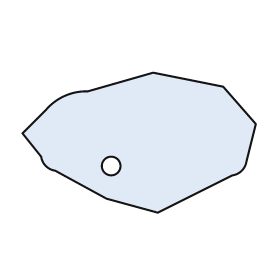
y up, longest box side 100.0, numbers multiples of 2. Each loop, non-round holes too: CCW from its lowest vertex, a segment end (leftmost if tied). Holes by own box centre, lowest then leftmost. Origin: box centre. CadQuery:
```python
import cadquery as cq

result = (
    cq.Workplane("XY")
    .moveTo(8.0, -30.0)
    .lineTo(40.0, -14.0)
    .threePointArc((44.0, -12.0), (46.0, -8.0))
    .lineTo(50.0, 8.0)
    .lineTo(36.0, 24.0)
    .lineTo(6.0, 30.0)
    .lineTo(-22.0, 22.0)
    .threePointArc((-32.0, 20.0), (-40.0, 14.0))
    .lineTo(-50.0, 4.0)
    .lineTo(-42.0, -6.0)
    .threePointArc((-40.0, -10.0), (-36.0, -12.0))
    .lineTo(-14.0, -24.0)
    .close()
    .moveTo(-12.0, -10.0)
    .circle(4.0)
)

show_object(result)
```